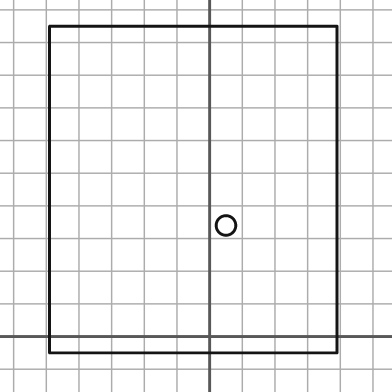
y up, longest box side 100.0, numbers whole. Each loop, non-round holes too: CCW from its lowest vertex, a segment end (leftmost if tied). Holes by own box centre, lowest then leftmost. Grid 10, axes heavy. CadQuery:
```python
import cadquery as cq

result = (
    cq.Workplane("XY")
    .moveTo(-49.0, -5.0)
    .lineTo(39.0, -5.0)
    .lineTo(39.0, 95.0)
    .lineTo(-49.0, 95.0)
    .close()
    .moveTo(5.0, 34.0)
    .circle(3.0)
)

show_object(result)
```